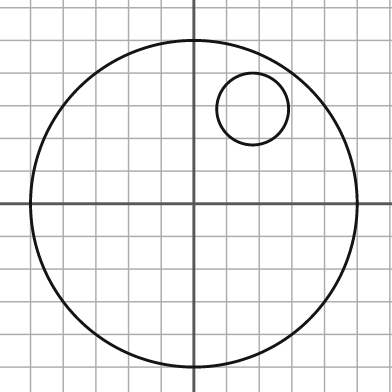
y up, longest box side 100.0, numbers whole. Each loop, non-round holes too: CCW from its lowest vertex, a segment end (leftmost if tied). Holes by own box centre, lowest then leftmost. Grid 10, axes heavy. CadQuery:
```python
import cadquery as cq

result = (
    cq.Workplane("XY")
    .moveTo(0.0, 0.0)
    .circle(50.0)
    .moveTo(18.0, 29.0)
    .circle(11.0)
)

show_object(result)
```